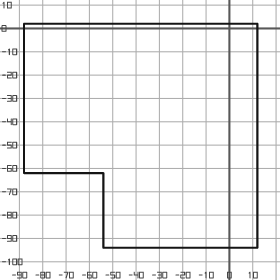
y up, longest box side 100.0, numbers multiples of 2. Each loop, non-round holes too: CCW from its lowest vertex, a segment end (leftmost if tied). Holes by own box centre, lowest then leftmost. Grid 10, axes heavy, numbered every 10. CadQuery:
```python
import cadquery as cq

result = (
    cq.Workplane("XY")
    .moveTo(-54.0, -94.0)
    .lineTo(12.0, -94.0)
    .lineTo(12.0, 2.0)
    .lineTo(-88.0, 2.0)
    .lineTo(-88.0, -62.0)
    .lineTo(-54.0, -62.0)
    .close()
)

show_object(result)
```